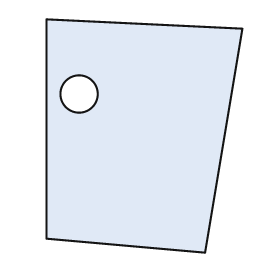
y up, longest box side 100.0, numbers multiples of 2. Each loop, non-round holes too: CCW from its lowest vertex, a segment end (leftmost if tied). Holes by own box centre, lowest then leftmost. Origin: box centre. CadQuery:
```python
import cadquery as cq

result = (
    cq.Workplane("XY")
    .moveTo(26.0, -50.0)
    .lineTo(42.0, 46.0)
    .lineTo(-42.0, 50.0)
    .lineTo(-42.0, -44.0)
    .close()
    .moveTo(-28.0, 18.0)
    .circle(8.0)
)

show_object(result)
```